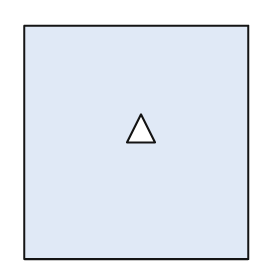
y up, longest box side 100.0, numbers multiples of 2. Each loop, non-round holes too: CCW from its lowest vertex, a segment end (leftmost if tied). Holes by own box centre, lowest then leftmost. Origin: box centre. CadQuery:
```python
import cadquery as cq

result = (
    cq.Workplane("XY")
    .moveTo(-48.0, -50.0)
    .lineTo(48.0, -50.0)
    .lineTo(48.0, 50.0)
    .lineTo(-48.0, 50.0)
    .close()
    .moveTo(-4.0, 0.0)
    .lineTo(8.0, 0.0)
    .lineTo(2.0, 12.0)
    .close()
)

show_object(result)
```